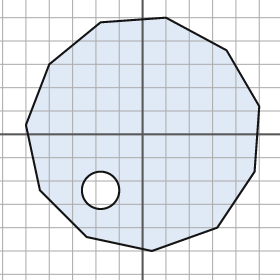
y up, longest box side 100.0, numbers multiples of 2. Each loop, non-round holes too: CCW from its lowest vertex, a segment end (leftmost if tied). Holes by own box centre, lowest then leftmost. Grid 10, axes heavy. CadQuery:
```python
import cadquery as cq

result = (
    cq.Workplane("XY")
    .moveTo(4.0, -50.0)
    .lineTo(32.0, -40.0)
    .lineTo(48.0, -16.0)
    .lineTo(50.0, 12.0)
    .lineTo(36.0, 36.0)
    .lineTo(10.0, 50.0)
    .lineTo(-18.0, 48.0)
    .lineTo(-40.0, 30.0)
    .lineTo(-50.0, 4.0)
    .lineTo(-44.0, -24.0)
    .lineTo(-24.0, -44.0)
    .close()
    .moveTo(-18.0, -24.0)
    .circle(8.0)
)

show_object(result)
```